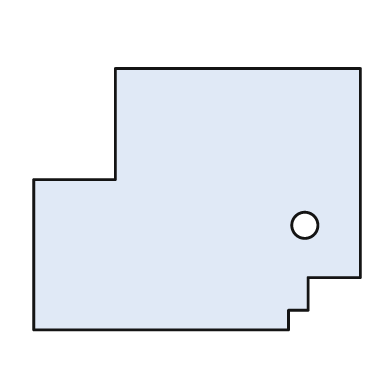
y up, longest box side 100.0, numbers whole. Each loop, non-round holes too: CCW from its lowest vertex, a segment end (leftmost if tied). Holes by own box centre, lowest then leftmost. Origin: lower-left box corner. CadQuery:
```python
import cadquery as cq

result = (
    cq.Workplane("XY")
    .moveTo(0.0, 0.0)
    .lineTo(78.0, 0.0)
    .lineTo(78.0, 6.0)
    .lineTo(84.0, 6.0)
    .lineTo(84.0, 16.0)
    .lineTo(100.0, 16.0)
    .lineTo(100.0, 80.0)
    .lineTo(25.0, 80.0)
    .lineTo(25.0, 46.0)
    .lineTo(0.0, 46.0)
    .close()
    .moveTo(83.0, 32.0)
    .circle(4.0)
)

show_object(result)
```